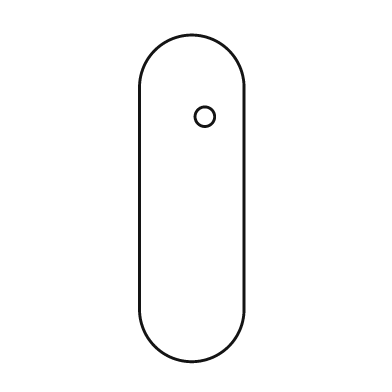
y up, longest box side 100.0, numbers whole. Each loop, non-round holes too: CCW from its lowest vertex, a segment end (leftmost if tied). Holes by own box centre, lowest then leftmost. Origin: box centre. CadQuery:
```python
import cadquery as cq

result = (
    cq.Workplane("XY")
    .moveTo(-16.0, -34.0)
    .threePointArc((0.0, -50.0), (16.0, -34.0))
    .lineTo(16.0, 34.0)
    .threePointArc((0.0, 50.0), (-16.0, 34.0))
    .close()
    .moveTo(4.0, 25.0)
    .circle(3.0)
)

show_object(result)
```